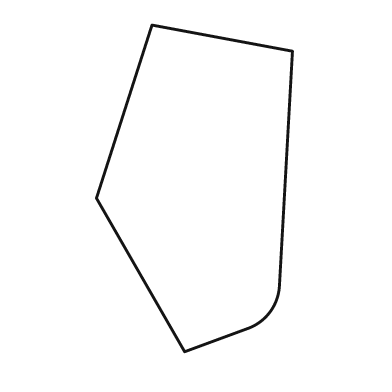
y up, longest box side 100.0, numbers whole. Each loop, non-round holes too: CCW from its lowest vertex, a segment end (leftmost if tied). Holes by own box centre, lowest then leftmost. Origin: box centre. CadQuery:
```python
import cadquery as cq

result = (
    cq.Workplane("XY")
    .moveTo(-3.0, -50.0)
    .lineTo(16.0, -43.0)
    .threePointArc((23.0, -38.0), (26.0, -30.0))
    .lineTo(30.0, 42.0)
    .lineTo(-13.0, 50.0)
    .lineTo(-30.0, -3.0)
    .close()
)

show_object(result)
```